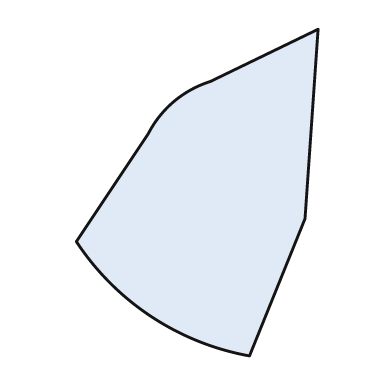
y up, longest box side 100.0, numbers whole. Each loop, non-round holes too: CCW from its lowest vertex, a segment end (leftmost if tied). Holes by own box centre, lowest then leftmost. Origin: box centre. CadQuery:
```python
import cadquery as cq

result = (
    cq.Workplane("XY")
    .moveTo(16.0, -50.0)
    .lineTo(33.0, -8.0)
    .lineTo(37.0, 50.0)
    .lineTo(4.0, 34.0)
    .threePointArc((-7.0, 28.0), (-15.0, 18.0))
    .lineTo(-37.0, -15.0)
    .threePointArc((-14.0, -38.0), (16.0, -50.0))
    .close()
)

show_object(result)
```